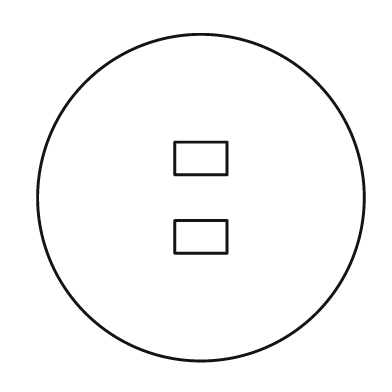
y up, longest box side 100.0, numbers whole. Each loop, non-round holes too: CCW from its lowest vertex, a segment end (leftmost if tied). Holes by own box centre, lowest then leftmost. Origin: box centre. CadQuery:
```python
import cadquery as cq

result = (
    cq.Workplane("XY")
    .moveTo(0.0, 0.0)
    .circle(50.0)
    .moveTo(-8.0, -17.0)
    .lineTo(8.0, -17.0)
    .lineTo(8.0, -7.0)
    .lineTo(-8.0, -7.0)
    .close()
    .moveTo(-8.0, 7.0)
    .lineTo(8.0, 7.0)
    .lineTo(8.0, 17.0)
    .lineTo(-8.0, 17.0)
    .close()
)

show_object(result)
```